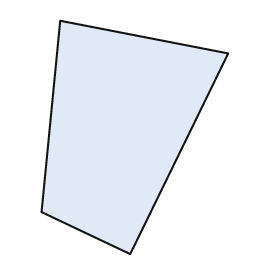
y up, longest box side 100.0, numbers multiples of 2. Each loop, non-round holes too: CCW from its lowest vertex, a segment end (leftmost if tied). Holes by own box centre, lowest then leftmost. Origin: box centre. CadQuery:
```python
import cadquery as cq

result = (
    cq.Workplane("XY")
    .moveTo(-2.0, -50.0)
    .lineTo(40.0, 36.0)
    .lineTo(-32.0, 50.0)
    .lineTo(-40.0, -32.0)
    .close()
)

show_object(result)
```